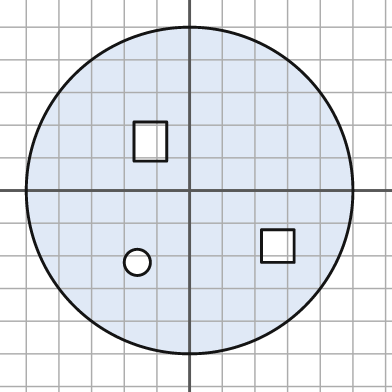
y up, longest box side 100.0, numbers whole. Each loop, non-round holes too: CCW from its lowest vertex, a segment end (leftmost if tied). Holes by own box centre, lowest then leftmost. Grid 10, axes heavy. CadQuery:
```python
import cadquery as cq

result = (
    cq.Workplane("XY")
    .moveTo(0.0, 0.0)
    .circle(50.0)
    .moveTo(-16.0, -22.0)
    .circle(4.0)
    .moveTo(22.0, -22.0)
    .lineTo(32.0, -22.0)
    .lineTo(32.0, -12.0)
    .lineTo(22.0, -12.0)
    .close()
    .moveTo(-17.0, 9.0)
    .lineTo(-7.0, 9.0)
    .lineTo(-7.0, 21.0)
    .lineTo(-17.0, 21.0)
    .close()
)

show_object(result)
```